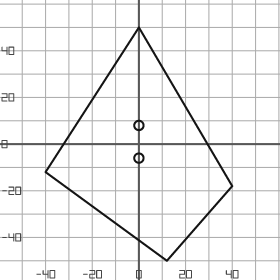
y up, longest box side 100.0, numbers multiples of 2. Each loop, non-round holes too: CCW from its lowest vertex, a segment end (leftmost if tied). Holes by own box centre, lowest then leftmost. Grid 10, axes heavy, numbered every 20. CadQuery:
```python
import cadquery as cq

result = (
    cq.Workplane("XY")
    .moveTo(12.0, -50.0)
    .lineTo(40.0, -18.0)
    .lineTo(0.0, 50.0)
    .lineTo(-40.0, -12.0)
    .close()
    .moveTo(0.0, -6.0)
    .circle(2.0)
    .moveTo(0.0, 8.0)
    .circle(2.0)
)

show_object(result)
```